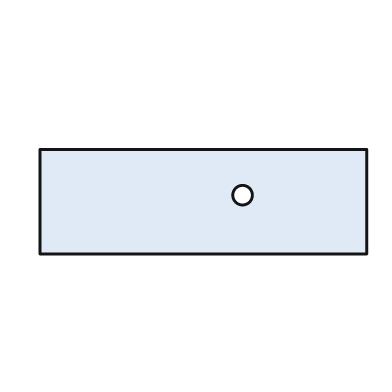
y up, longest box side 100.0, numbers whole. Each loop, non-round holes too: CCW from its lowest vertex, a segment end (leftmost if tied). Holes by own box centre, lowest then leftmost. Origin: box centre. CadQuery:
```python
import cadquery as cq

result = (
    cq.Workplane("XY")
    .moveTo(-50.0, -16.0)
    .lineTo(50.0, -16.0)
    .lineTo(50.0, 16.0)
    .lineTo(-50.0, 16.0)
    .close()
    .moveTo(12.0, 2.0)
    .circle(3.0)
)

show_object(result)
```